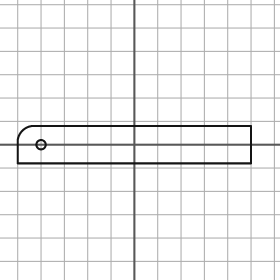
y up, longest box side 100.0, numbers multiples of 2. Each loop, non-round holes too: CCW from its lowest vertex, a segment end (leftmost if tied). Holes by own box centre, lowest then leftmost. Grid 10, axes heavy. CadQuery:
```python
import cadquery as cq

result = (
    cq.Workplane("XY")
    .moveTo(-50.0, -8.0)
    .lineTo(50.0, -8.0)
    .lineTo(50.0, 8.0)
    .lineTo(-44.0, 8.0)
    .threePointArc((-48.0, 6.0), (-50.0, 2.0))
    .close()
    .moveTo(-40.0, 0.0)
    .circle(2.0)
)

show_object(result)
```